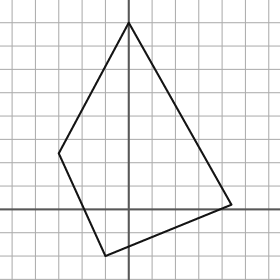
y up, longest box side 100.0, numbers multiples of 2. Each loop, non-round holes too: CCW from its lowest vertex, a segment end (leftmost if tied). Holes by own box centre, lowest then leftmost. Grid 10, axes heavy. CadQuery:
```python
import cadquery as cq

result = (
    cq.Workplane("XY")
    .moveTo(-10.0, -20.0)
    .lineTo(44.0, 2.0)
    .lineTo(0.0, 80.0)
    .lineTo(-30.0, 24.0)
    .close()
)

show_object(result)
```